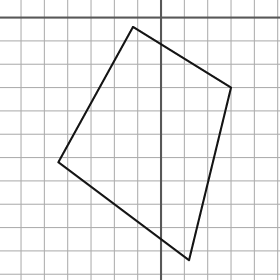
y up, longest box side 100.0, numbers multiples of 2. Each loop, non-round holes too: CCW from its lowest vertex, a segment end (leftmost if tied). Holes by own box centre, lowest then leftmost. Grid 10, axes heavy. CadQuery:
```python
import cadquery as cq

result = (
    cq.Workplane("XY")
    .moveTo(12.0, -104.0)
    .lineTo(30.0, -30.0)
    .lineTo(-12.0, -4.0)
    .lineTo(-44.0, -62.0)
    .close()
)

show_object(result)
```